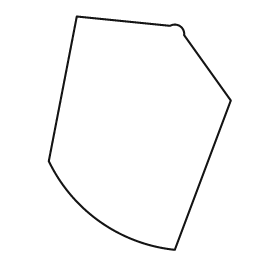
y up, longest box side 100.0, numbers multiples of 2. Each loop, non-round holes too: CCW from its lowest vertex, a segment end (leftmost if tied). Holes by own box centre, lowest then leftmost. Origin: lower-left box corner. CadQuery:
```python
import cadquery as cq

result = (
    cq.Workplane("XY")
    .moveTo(54.0, 0.0)
    .lineTo(78.0, 64.0)
    .lineTo(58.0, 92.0)
    .threePointArc((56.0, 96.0), (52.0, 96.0))
    .lineTo(12.0, 100.0)
    .lineTo(0.0, 38.0)
    .threePointArc((22.0, 12.0), (54.0, 0.0))
    .close()
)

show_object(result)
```